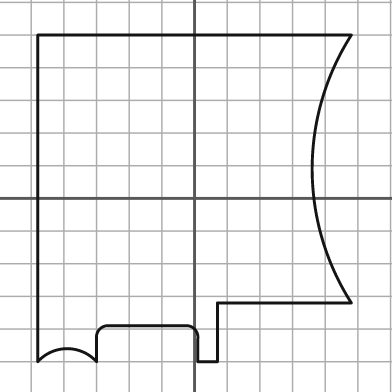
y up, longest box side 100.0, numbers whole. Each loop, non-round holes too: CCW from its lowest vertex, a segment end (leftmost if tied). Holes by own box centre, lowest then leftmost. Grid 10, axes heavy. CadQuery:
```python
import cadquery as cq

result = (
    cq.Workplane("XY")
    .moveTo(-48.0, -50.0)
    .threePointArc((-39.0, -46.0), (-30.0, -50.0))
    .lineTo(-30.0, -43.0)
    .threePointArc((-29.0, -40.0), (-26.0, -39.0))
    .lineTo(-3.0, -39.0)
    .threePointArc((0.0, -40.0), (1.0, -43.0))
    .lineTo(1.0, -50.0)
    .lineTo(7.0, -50.0)
    .lineTo(7.0, -32.0)
    .lineTo(48.0, -32.0)
    .threePointArc((36.0, 9.0), (48.0, 50.0))
    .lineTo(-48.0, 50.0)
    .close()
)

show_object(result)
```